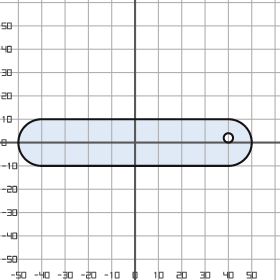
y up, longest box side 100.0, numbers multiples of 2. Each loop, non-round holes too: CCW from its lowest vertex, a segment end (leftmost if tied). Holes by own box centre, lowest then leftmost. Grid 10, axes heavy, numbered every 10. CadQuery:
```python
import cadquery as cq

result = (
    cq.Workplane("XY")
    .moveTo(-40.0, -10.0)
    .lineTo(40.0, -10.0)
    .threePointArc((50.0, 0.0), (40.0, 10.0))
    .lineTo(-40.0, 10.0)
    .threePointArc((-50.0, 0.0), (-40.0, -10.0))
    .close()
    .moveTo(40.0, 2.0)
    .circle(2.0)
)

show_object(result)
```